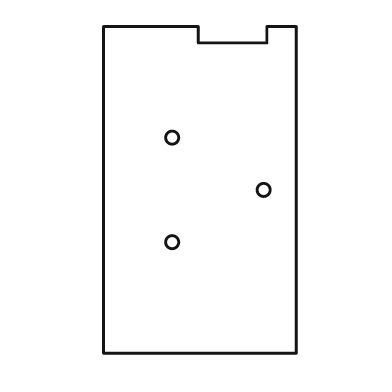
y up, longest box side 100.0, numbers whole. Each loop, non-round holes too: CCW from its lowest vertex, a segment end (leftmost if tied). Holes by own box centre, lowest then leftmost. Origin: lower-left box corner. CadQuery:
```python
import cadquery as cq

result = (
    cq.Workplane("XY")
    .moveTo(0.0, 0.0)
    .lineTo(59.0, 0.0)
    .lineTo(59.0, 100.0)
    .lineTo(50.0, 100.0)
    .lineTo(50.0, 95.0)
    .lineTo(29.0, 95.0)
    .lineTo(29.0, 100.0)
    .lineTo(0.0, 100.0)
    .close()
    .moveTo(21.0, 34.0)
    .circle(2.0)
    .moveTo(49.0, 50.0)
    .circle(2.0)
    .moveTo(21.0, 66.0)
    .circle(2.0)
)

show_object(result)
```